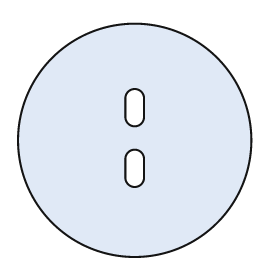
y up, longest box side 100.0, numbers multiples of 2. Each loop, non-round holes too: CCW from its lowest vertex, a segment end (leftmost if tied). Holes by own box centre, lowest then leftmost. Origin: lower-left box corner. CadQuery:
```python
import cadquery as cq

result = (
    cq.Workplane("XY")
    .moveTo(50.0, 50.0)
    .circle(50.0)
    .moveTo(46.0, 34.0)
    .threePointArc((50.0, 30.0), (54.0, 34.0))
    .lineTo(54.0, 42.0)
    .threePointArc((50.0, 46.0), (46.0, 42.0))
    .close()
    .moveTo(46.0, 60.0)
    .threePointArc((50.0, 56.0), (54.0, 60.0))
    .lineTo(54.0, 68.0)
    .threePointArc((50.0, 72.0), (46.0, 68.0))
    .close()
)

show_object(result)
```